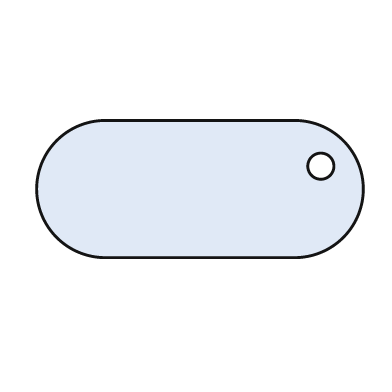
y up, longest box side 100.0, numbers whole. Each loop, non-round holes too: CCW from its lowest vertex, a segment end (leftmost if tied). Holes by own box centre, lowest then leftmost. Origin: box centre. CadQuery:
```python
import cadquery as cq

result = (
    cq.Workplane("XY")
    .moveTo(-29.0, -21.0)
    .lineTo(29.0, -21.0)
    .threePointArc((50.0, 0.0), (29.0, 21.0))
    .lineTo(-29.0, 21.0)
    .threePointArc((-50.0, 0.0), (-29.0, -21.0))
    .close()
    .moveTo(37.0, 7.0)
    .circle(4.0)
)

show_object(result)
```